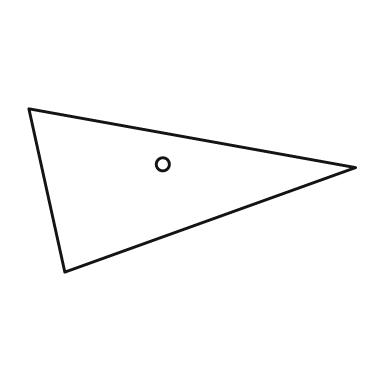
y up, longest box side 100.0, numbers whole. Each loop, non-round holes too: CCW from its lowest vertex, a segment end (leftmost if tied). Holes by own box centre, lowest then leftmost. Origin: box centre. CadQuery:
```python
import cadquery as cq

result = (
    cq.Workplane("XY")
    .moveTo(-39.0, -25.0)
    .lineTo(50.0, 7.0)
    .lineTo(-50.0, 25.0)
    .close()
    .moveTo(-9.0, 8.0)
    .circle(2.0)
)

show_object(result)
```